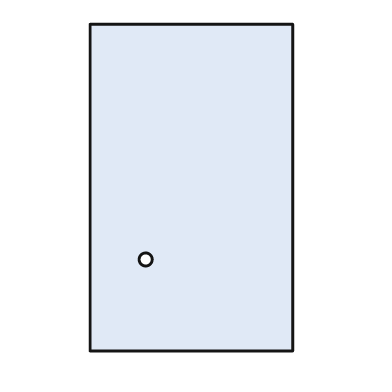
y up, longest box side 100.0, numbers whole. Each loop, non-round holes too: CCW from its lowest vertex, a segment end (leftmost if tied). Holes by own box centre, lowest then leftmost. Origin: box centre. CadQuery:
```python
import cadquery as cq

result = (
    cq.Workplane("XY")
    .moveTo(-31.0, -50.0)
    .lineTo(31.0, -50.0)
    .lineTo(31.0, 50.0)
    .lineTo(-31.0, 50.0)
    .close()
    .moveTo(-14.0, -22.0)
    .circle(2.0)
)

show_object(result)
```